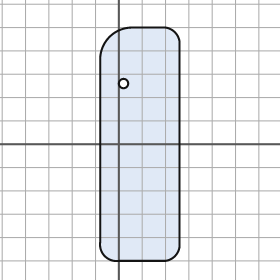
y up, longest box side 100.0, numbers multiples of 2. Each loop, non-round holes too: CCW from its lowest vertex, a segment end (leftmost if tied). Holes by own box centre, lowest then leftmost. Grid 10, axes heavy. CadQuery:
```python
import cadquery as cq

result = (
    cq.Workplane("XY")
    .moveTo(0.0, -50.0)
    .lineTo(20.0, -50.0)
    .threePointArc((24.0, -48.0), (26.0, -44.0))
    .lineTo(26.0, 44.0)
    .threePointArc((24.0, 48.0), (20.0, 50.0))
    .lineTo(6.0, 50.0)
    .threePointArc((-4.0, 46.0), (-8.0, 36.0))
    .lineTo(-8.0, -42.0)
    .threePointArc((-6.0, -48.0), (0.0, -50.0))
    .close()
    .moveTo(2.0, 26.0)
    .circle(2.0)
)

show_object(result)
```